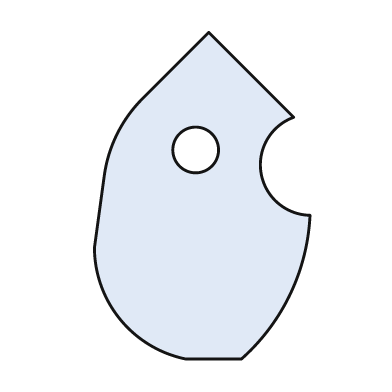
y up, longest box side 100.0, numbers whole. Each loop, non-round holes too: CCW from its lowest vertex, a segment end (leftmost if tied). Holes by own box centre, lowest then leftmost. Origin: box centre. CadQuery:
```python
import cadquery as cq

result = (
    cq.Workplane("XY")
    .moveTo(-5.0, -50.0)
    .lineTo(12.0, -50.0)
    .threePointArc((27.0, -30.0), (33.0, -6.0))
    .threePointArc((18.0, 7.0), (28.0, 24.0))
    .lineTo(2.0, 50.0)
    .lineTo(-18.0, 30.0)
    .threePointArc((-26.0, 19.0), (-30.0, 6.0))
    .lineTo(-33.0, -16.0)
    .threePointArc((-25.0, -38.0), (-5.0, -50.0))
    .close()
    .moveTo(-2.0, 14.0)
    .circle(7.0)
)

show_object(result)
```